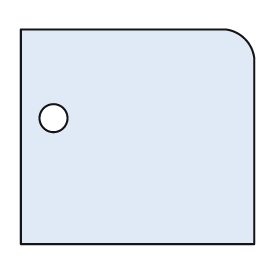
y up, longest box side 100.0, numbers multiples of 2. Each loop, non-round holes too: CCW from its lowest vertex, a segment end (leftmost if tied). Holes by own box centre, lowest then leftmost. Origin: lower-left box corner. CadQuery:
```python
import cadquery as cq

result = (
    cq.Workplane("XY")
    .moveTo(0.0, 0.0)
    .lineTo(100.0, 0.0)
    .lineTo(100.0, 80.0)
    .threePointArc((96.0, 88.0), (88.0, 92.0))
    .lineTo(0.0, 92.0)
    .close()
    .moveTo(14.0, 54.0)
    .circle(6.0)
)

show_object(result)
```